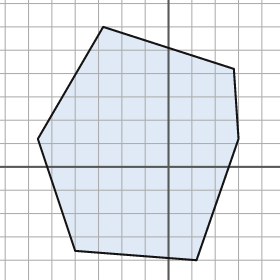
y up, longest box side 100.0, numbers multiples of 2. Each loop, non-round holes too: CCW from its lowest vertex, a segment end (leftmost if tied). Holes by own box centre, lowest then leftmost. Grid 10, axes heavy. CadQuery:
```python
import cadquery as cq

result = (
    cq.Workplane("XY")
    .moveTo(12.0, -40.0)
    .lineTo(30.0, 12.0)
    .lineTo(28.0, 42.0)
    .lineTo(-28.0, 60.0)
    .lineTo(-56.0, 12.0)
    .lineTo(-40.0, -36.0)
    .close()
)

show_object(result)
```